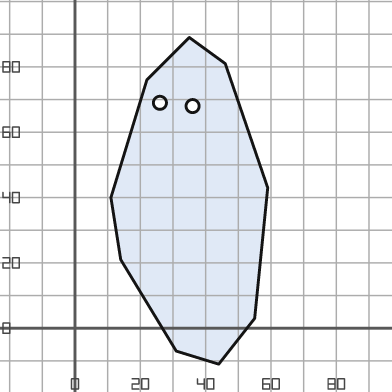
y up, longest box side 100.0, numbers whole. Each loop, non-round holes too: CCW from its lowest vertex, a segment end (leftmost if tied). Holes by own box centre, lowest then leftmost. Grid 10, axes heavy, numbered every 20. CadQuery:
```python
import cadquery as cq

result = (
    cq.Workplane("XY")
    .moveTo(44.0, -11.0)
    .lineTo(55.0, 3.0)
    .lineTo(59.0, 43.0)
    .lineTo(46.0, 81.0)
    .lineTo(35.0, 89.0)
    .lineTo(22.0, 76.0)
    .lineTo(11.0, 40.0)
    .lineTo(14.0, 21.0)
    .lineTo(31.0, -7.0)
    .close()
    .moveTo(36.0, 68.0)
    .circle(2.0)
    .moveTo(26.0, 69.0)
    .circle(2.0)
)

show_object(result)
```